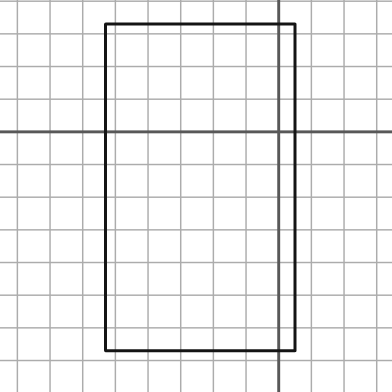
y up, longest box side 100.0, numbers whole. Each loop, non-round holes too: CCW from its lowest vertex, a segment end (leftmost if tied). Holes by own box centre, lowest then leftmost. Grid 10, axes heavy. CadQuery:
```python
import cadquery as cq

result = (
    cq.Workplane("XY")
    .moveTo(-53.0, -67.0)
    .lineTo(5.0, -67.0)
    .lineTo(5.0, 33.0)
    .lineTo(-53.0, 33.0)
    .close()
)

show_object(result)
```